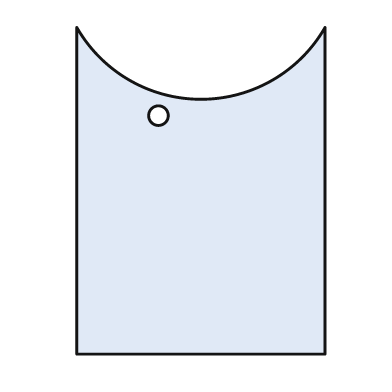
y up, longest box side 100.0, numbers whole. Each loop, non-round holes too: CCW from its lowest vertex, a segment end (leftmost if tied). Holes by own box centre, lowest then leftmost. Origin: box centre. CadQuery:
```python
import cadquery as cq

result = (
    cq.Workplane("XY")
    .moveTo(-38.0, -50.0)
    .lineTo(38.0, -50.0)
    .lineTo(38.0, 50.0)
    .threePointArc((0.0, 28.0), (-38.0, 50.0))
    .close()
    .moveTo(-13.0, 23.0)
    .circle(3.0)
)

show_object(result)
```